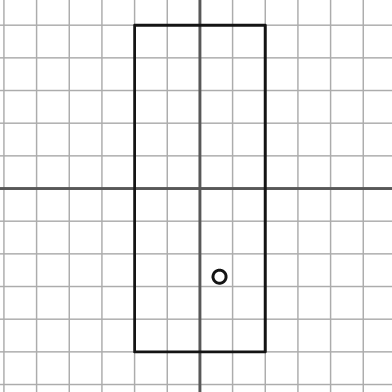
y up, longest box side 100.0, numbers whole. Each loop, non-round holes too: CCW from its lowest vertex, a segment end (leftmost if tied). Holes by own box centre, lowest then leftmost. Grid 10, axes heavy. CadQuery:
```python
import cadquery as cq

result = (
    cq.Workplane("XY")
    .moveTo(-20.0, -50.0)
    .lineTo(20.0, -50.0)
    .lineTo(20.0, 50.0)
    .lineTo(-20.0, 50.0)
    .close()
    .moveTo(6.0, -27.0)
    .circle(2.0)
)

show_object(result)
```